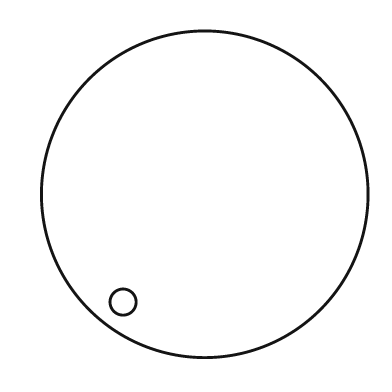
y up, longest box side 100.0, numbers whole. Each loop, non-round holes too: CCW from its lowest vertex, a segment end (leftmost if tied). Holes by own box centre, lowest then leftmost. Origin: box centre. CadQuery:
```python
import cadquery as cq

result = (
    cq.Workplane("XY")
    .moveTo(0.0, 0.0)
    .circle(50.0)
    .moveTo(-25.0, -33.0)
    .circle(4.0)
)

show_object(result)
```